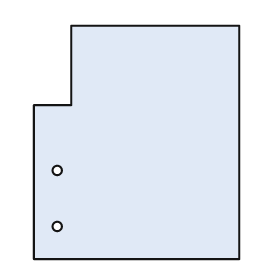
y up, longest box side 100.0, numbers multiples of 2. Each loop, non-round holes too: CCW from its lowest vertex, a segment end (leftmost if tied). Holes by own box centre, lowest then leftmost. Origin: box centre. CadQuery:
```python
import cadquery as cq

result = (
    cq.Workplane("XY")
    .moveTo(-44.0, -50.0)
    .lineTo(44.0, -50.0)
    .lineTo(44.0, 50.0)
    .lineTo(-28.0, 50.0)
    .lineTo(-28.0, 16.0)
    .lineTo(-44.0, 16.0)
    .close()
    .moveTo(-34.0, -36.0)
    .circle(2.0)
    .moveTo(-34.0, -12.0)
    .circle(2.0)
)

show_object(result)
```